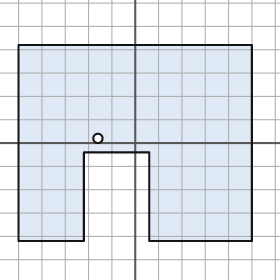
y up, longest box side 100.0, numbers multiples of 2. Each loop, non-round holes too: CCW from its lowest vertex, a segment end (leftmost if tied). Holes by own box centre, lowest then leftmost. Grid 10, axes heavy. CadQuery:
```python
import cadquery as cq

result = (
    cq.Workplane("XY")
    .moveTo(-50.0, -42.0)
    .lineTo(-22.0, -42.0)
    .lineTo(-22.0, -4.0)
    .lineTo(6.0, -4.0)
    .lineTo(6.0, -42.0)
    .lineTo(50.0, -42.0)
    .lineTo(50.0, 42.0)
    .lineTo(-50.0, 42.0)
    .close()
    .moveTo(-16.0, 2.0)
    .circle(2.0)
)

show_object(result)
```